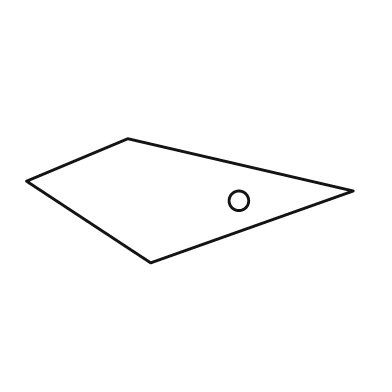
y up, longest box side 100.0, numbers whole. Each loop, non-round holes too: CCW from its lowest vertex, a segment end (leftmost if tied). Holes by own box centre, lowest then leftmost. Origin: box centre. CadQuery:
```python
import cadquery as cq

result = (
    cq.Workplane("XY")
    .moveTo(-12.0, -19.0)
    .lineTo(50.0, 3.0)
    .lineTo(-19.0, 19.0)
    .lineTo(-50.0, 6.0)
    .close()
    .moveTo(15.0, 0.0)
    .circle(3.0)
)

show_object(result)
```